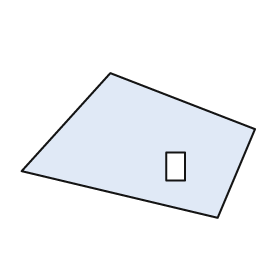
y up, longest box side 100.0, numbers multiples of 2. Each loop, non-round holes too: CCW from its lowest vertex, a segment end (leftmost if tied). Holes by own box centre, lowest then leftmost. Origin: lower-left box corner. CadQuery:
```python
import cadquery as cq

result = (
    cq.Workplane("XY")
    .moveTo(84.0, 0.0)
    .lineTo(100.0, 38.0)
    .lineTo(38.0, 62.0)
    .lineTo(0.0, 20.0)
    .close()
    .moveTo(62.0, 16.0)
    .lineTo(70.0, 16.0)
    .lineTo(70.0, 28.0)
    .lineTo(62.0, 28.0)
    .close()
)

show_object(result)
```